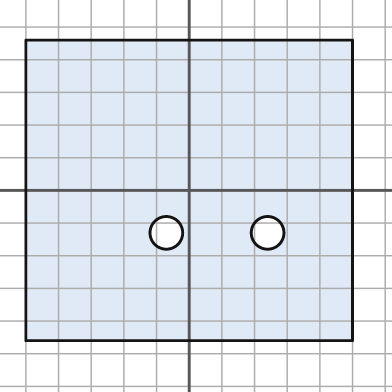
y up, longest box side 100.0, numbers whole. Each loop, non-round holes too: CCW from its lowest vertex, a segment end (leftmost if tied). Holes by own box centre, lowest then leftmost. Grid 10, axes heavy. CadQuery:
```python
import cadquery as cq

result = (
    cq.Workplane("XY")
    .moveTo(-50.0, -46.0)
    .lineTo(50.0, -46.0)
    .lineTo(50.0, 46.0)
    .lineTo(-50.0, 46.0)
    .close()
    .moveTo(-7.0, -13.0)
    .circle(5.0)
    .moveTo(24.0, -13.0)
    .circle(5.0)
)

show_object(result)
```